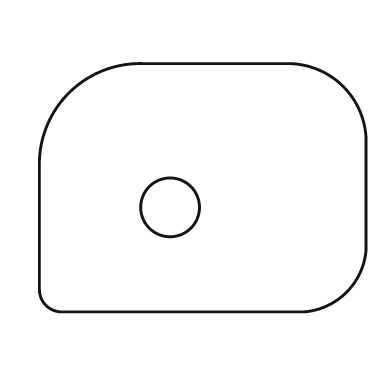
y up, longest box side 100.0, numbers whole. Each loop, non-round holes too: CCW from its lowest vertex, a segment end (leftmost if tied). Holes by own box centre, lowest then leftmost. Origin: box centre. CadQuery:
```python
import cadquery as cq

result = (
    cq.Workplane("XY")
    .moveTo(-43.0, -38.0)
    .lineTo(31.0, -38.0)
    .threePointArc((44.0, -32.0), (50.0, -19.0))
    .lineTo(50.0, 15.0)
    .threePointArc((43.0, 31.0), (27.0, 38.0))
    .lineTo(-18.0, 38.0)
    .threePointArc((-41.0, 29.0), (-50.0, 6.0))
    .lineTo(-50.0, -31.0)
    .threePointArc((-48.0, -36.0), (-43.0, -38.0))
    .close()
    .moveTo(-10.0, -6.0)
    .circle(9.0)
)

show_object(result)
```